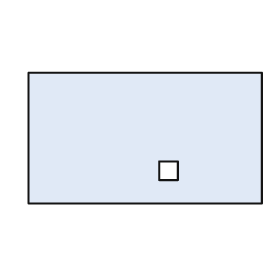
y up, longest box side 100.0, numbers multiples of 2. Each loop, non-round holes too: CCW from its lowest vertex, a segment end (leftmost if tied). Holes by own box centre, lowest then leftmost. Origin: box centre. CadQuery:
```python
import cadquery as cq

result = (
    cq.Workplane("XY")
    .moveTo(-50.0, -28.0)
    .lineTo(50.0, -28.0)
    .lineTo(50.0, 28.0)
    .lineTo(-50.0, 28.0)
    .close()
    .moveTo(6.0, -18.0)
    .lineTo(14.0, -18.0)
    .lineTo(14.0, -10.0)
    .lineTo(6.0, -10.0)
    .close()
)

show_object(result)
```